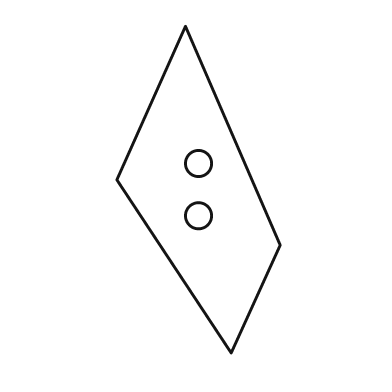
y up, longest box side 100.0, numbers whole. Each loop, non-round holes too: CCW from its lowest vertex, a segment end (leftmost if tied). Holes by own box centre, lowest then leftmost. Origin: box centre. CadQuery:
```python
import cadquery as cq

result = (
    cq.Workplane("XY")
    .moveTo(10.0, -50.0)
    .lineTo(25.0, -17.0)
    .lineTo(-4.0, 50.0)
    .lineTo(-25.0, 3.0)
    .close()
    .moveTo(0.0, -8.0)
    .circle(4.0)
    .moveTo(0.0, 8.0)
    .circle(4.0)
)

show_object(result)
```